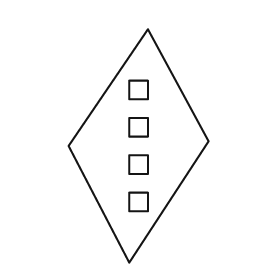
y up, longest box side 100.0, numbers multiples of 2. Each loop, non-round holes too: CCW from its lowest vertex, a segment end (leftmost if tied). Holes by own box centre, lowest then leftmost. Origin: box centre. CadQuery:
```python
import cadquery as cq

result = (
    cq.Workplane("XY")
    .moveTo(-4.0, -50.0)
    .lineTo(30.0, 2.0)
    .lineTo(4.0, 50.0)
    .lineTo(-30.0, 0.0)
    .close()
    .moveTo(-4.0, -28.0)
    .lineTo(4.0, -28.0)
    .lineTo(4.0, -20.0)
    .lineTo(-4.0, -20.0)
    .close()
    .moveTo(-4.0, -12.0)
    .lineTo(4.0, -12.0)
    .lineTo(4.0, -4.0)
    .lineTo(-4.0, -4.0)
    .close()
    .moveTo(-4.0, 4.0)
    .lineTo(4.0, 4.0)
    .lineTo(4.0, 12.0)
    .lineTo(-4.0, 12.0)
    .close()
    .moveTo(-4.0, 20.0)
    .lineTo(4.0, 20.0)
    .lineTo(4.0, 28.0)
    .lineTo(-4.0, 28.0)
    .close()
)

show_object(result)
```